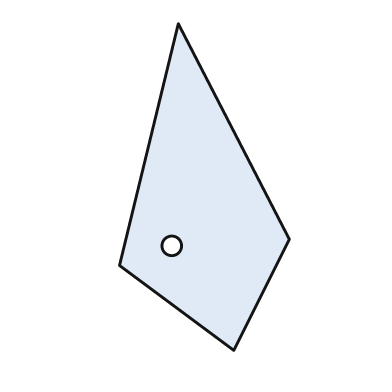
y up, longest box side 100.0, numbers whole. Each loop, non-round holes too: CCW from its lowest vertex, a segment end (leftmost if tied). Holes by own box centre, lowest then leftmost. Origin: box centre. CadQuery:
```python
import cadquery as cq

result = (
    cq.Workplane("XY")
    .moveTo(9.0, -50.0)
    .lineTo(26.0, -16.0)
    .lineTo(-8.0, 50.0)
    .lineTo(-26.0, -24.0)
    .close()
    .moveTo(-10.0, -18.0)
    .circle(3.0)
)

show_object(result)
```